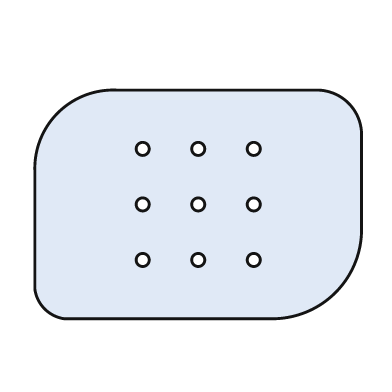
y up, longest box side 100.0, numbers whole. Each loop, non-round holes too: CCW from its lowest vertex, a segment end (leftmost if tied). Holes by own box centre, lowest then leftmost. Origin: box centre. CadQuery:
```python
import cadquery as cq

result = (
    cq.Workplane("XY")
    .moveTo(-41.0, -35.0)
    .lineTo(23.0, -35.0)
    .threePointArc((42.0, -27.0), (50.0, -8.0))
    .lineTo(50.0, 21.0)
    .threePointArc((46.0, 31.0), (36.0, 35.0))
    .lineTo(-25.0, 35.0)
    .threePointArc((-43.0, 28.0), (-50.0, 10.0))
    .lineTo(-50.0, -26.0)
    .threePointArc((-47.0, -32.0), (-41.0, -35.0))
    .close()
    .moveTo(-17.0, -17.0)
    .circle(2.0)
    .moveTo(0.0, -17.0)
    .circle(2.0)
    .moveTo(17.0, -17.0)
    .circle(2.0)
    .moveTo(-17.0, 0.0)
    .circle(2.0)
    .moveTo(0.0, 0.0)
    .circle(2.0)
    .moveTo(17.0, 0.0)
    .circle(2.0)
    .moveTo(-17.0, 17.0)
    .circle(2.0)
    .moveTo(0.0, 17.0)
    .circle(2.0)
    .moveTo(17.0, 17.0)
    .circle(2.0)
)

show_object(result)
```